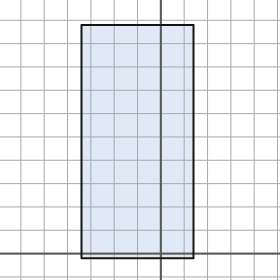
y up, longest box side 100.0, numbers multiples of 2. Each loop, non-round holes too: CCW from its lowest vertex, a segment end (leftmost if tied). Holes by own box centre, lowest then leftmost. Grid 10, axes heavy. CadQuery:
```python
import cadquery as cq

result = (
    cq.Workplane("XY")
    .moveTo(-34.0, -2.0)
    .lineTo(14.0, -2.0)
    .lineTo(14.0, 98.0)
    .lineTo(-34.0, 98.0)
    .close()
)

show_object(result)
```